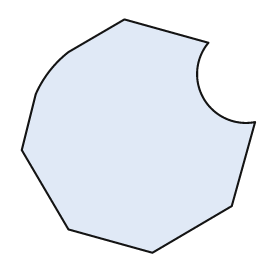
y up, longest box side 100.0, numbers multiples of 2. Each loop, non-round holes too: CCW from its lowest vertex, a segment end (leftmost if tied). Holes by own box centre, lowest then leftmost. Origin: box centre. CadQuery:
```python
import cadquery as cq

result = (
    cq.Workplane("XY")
    .moveTo(6.0, -50.0)
    .lineTo(40.0, -30.0)
    .lineTo(50.0, 6.0)
    .threePointArc((28.0, 16.0), (30.0, 40.0))
    .lineTo(-6.0, 50.0)
    .lineTo(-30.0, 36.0)
    .threePointArc((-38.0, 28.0), (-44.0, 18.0))
    .lineTo(-50.0, -6.0)
    .lineTo(-30.0, -40.0)
    .close()
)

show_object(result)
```